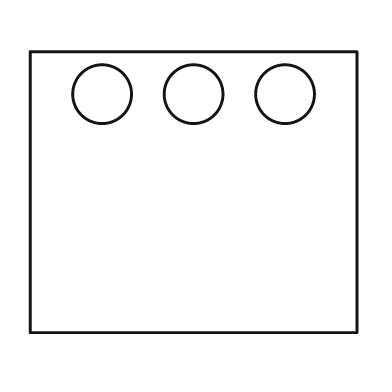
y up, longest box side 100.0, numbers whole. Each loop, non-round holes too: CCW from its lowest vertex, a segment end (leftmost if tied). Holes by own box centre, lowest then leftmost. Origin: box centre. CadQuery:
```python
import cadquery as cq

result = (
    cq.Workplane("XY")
    .moveTo(-50.0, -43.0)
    .lineTo(50.0, -43.0)
    .lineTo(50.0, 43.0)
    .lineTo(-50.0, 43.0)
    .close()
    .moveTo(-28.0, 30.0)
    .circle(9.0)
    .moveTo(0.0, 30.0)
    .circle(9.0)
    .moveTo(28.0, 30.0)
    .circle(9.0)
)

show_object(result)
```